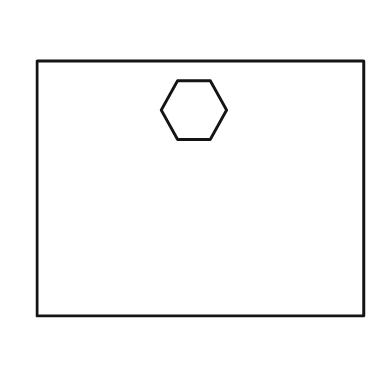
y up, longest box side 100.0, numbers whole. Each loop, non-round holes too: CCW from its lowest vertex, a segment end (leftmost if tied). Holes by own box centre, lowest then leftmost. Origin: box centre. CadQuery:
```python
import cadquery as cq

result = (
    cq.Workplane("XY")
    .moveTo(-50.0, -39.0)
    .lineTo(50.0, -39.0)
    .lineTo(50.0, 39.0)
    .lineTo(-50.0, 39.0)
    .close()
    .moveTo(-7.0, 15.0)
    .lineTo(3.0, 15.0)
    .lineTo(8.0, 24.0)
    .lineTo(3.0, 33.0)
    .lineTo(-7.0, 33.0)
    .lineTo(-12.0, 24.0)
    .close()
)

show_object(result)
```